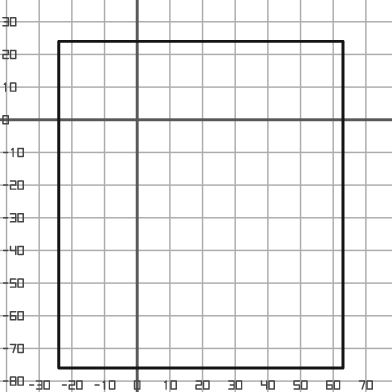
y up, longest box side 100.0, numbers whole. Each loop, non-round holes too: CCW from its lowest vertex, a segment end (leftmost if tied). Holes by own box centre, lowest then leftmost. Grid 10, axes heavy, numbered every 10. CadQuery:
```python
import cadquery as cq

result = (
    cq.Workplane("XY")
    .moveTo(-24.0, -76.0)
    .lineTo(63.0, -76.0)
    .lineTo(63.0, 24.0)
    .lineTo(-24.0, 24.0)
    .close()
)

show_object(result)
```